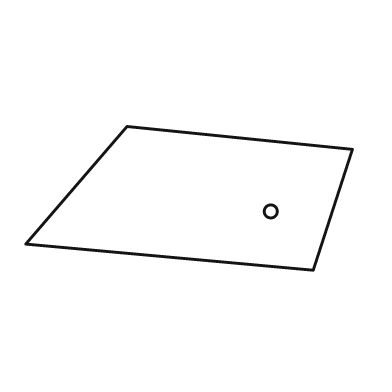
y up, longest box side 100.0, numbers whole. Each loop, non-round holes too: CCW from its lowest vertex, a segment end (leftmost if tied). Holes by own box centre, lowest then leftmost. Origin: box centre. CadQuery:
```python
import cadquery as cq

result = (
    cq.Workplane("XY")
    .moveTo(38.0, -22.0)
    .lineTo(50.0, 15.0)
    .lineTo(-19.0, 22.0)
    .lineTo(-50.0, -14.0)
    .close()
    .moveTo(25.0, -4.0)
    .circle(2.0)
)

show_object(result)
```